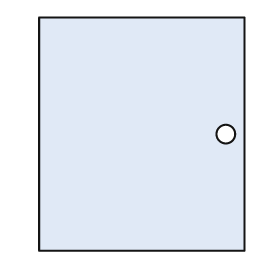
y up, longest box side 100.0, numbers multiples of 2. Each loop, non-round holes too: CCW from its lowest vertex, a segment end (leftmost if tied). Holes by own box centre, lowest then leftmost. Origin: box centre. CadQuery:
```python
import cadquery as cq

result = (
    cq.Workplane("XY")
    .moveTo(-44.0, -50.0)
    .lineTo(44.0, -50.0)
    .lineTo(44.0, 50.0)
    .lineTo(-44.0, 50.0)
    .close()
    .moveTo(36.0, 0.0)
    .circle(4.0)
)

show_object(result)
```